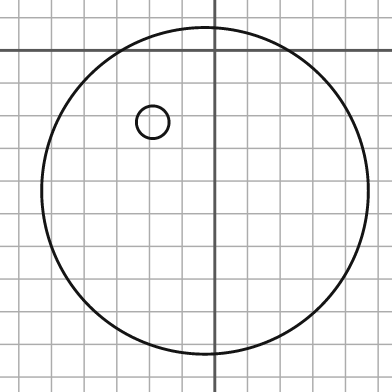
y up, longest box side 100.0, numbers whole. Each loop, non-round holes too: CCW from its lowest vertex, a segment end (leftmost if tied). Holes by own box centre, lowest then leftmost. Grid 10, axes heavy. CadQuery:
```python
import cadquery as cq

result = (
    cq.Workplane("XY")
    .moveTo(-3.0, -43.0)
    .circle(50.0)
    .moveTo(-19.0, -22.0)
    .circle(5.0)
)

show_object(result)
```